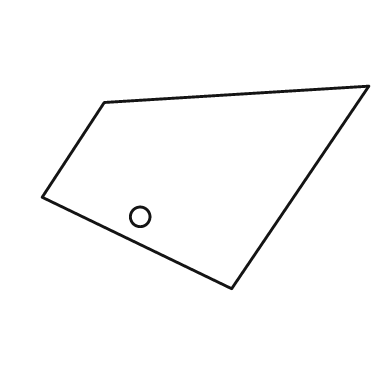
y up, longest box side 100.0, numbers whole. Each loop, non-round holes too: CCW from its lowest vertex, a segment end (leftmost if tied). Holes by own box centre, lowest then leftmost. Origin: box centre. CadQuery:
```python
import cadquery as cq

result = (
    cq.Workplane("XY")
    .moveTo(8.0, -31.0)
    .lineTo(50.0, 31.0)
    .lineTo(-31.0, 26.0)
    .lineTo(-50.0, -3.0)
    .close()
    .moveTo(-20.0, -9.0)
    .circle(3.0)
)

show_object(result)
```